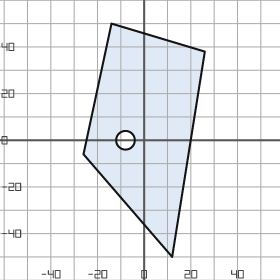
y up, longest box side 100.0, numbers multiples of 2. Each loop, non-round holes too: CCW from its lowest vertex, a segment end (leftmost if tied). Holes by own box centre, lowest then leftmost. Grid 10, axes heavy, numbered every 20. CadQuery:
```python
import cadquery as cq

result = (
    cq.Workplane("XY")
    .moveTo(12.0, -50.0)
    .lineTo(26.0, 38.0)
    .lineTo(-14.0, 50.0)
    .lineTo(-26.0, -6.0)
    .close()
    .moveTo(-8.0, 0.0)
    .circle(4.0)
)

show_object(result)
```